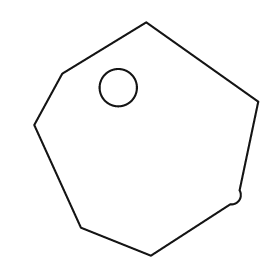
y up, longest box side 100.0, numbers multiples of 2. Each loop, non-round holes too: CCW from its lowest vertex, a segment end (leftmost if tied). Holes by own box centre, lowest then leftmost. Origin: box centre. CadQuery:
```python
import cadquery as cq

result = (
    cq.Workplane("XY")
    .moveTo(2.0, -50.0)
    .lineTo(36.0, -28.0)
    .threePointArc((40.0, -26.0), (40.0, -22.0))
    .lineTo(48.0, 16.0)
    .lineTo(0.0, 50.0)
    .lineTo(-36.0, 28.0)
    .lineTo(-48.0, 6.0)
    .lineTo(-28.0, -38.0)
    .close()
    .moveTo(-12.0, 22.0)
    .circle(8.0)
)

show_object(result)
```